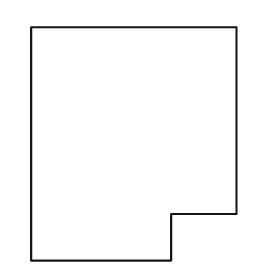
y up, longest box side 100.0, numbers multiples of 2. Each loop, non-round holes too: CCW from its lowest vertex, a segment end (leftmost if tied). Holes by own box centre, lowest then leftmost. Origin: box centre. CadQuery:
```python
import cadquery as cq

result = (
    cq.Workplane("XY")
    .moveTo(-44.0, -50.0)
    .lineTo(16.0, -50.0)
    .lineTo(16.0, -30.0)
    .lineTo(44.0, -30.0)
    .lineTo(44.0, 50.0)
    .lineTo(-44.0, 50.0)
    .close()
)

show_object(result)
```